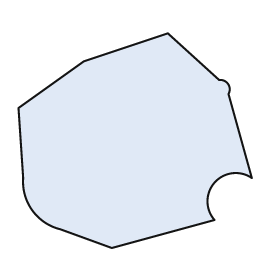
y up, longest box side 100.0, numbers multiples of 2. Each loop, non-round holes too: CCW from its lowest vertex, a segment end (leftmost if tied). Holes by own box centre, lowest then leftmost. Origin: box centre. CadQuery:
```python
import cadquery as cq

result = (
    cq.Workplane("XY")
    .moveTo(-10.0, -46.0)
    .lineTo(34.0, -34.0)
    .threePointArc((34.0, -18.0), (50.0, -16.0))
    .lineTo(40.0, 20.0)
    .threePointArc((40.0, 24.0), (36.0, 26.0))
    .lineTo(14.0, 46.0)
    .lineTo(-22.0, 34.0)
    .lineTo(-50.0, 14.0)
    .lineTo(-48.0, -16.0)
    .threePointArc((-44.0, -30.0), (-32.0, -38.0))
    .close()
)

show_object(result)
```